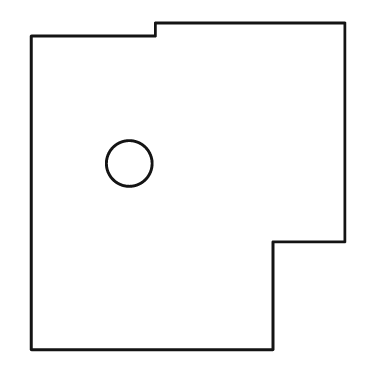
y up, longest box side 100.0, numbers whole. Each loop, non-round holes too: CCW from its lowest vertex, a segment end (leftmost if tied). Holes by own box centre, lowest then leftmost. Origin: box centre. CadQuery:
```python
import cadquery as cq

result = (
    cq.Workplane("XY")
    .moveTo(-48.0, -50.0)
    .lineTo(26.0, -50.0)
    .lineTo(26.0, -17.0)
    .lineTo(48.0, -17.0)
    .lineTo(48.0, 50.0)
    .lineTo(-10.0, 50.0)
    .lineTo(-10.0, 46.0)
    .lineTo(-48.0, 46.0)
    .close()
    .moveTo(-18.0, 7.0)
    .circle(7.0)
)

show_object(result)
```